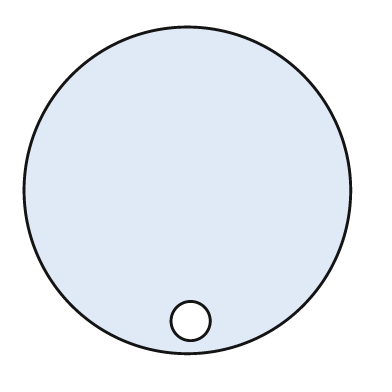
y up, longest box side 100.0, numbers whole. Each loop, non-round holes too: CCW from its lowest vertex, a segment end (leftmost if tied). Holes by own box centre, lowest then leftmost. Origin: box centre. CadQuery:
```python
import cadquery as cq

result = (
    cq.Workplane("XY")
    .moveTo(0.0, 0.0)
    .circle(50.0)
    .moveTo(1.0, -40.0)
    .circle(6.0)
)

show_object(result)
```